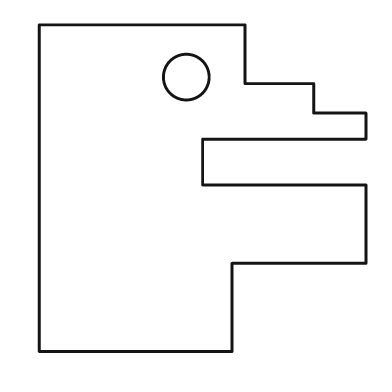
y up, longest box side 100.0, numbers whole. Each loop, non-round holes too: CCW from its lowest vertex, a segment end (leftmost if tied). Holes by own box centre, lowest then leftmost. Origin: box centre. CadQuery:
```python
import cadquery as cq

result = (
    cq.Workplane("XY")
    .moveTo(-50.0, -50.0)
    .lineTo(9.0, -50.0)
    .lineTo(9.0, -23.0)
    .lineTo(50.0, -23.0)
    .lineTo(50.0, 1.0)
    .lineTo(0.0, 1.0)
    .lineTo(0.0, 15.0)
    .lineTo(50.0, 15.0)
    .lineTo(50.0, 23.0)
    .lineTo(34.0, 23.0)
    .lineTo(34.0, 32.0)
    .lineTo(13.0, 32.0)
    .lineTo(13.0, 50.0)
    .lineTo(-50.0, 50.0)
    .close()
    .moveTo(-5.0, 34.0)
    .circle(7.0)
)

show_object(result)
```